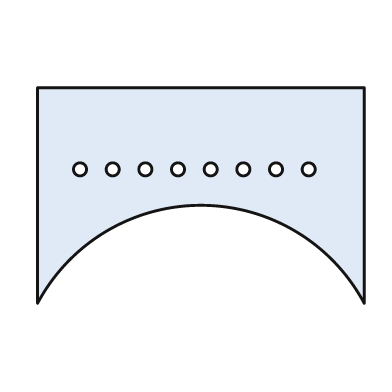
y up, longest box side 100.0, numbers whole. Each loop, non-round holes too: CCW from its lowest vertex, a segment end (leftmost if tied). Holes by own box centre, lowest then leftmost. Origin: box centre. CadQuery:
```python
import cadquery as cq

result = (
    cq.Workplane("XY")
    .moveTo(-50.0, -33.0)
    .threePointArc((0.0, -3.0), (50.0, -33.0))
    .lineTo(50.0, 33.0)
    .lineTo(-50.0, 33.0)
    .close()
    .moveTo(-37.0, 8.0)
    .circle(2.0)
    .moveTo(-27.0, 8.0)
    .circle(2.0)
    .moveTo(-17.0, 8.0)
    .circle(2.0)
    .moveTo(-7.0, 8.0)
    .circle(2.0)
    .moveTo(3.0, 8.0)
    .circle(2.0)
    .moveTo(13.0, 8.0)
    .circle(2.0)
    .moveTo(23.0, 8.0)
    .circle(2.0)
    .moveTo(33.0, 8.0)
    .circle(2.0)
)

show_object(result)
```